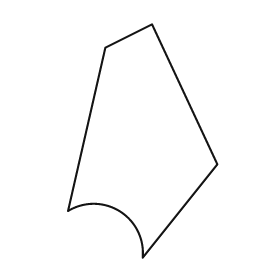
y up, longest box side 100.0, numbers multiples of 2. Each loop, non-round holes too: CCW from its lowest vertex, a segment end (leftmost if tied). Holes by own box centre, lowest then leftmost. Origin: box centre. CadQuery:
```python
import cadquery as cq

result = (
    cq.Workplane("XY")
    .moveTo(0.0, -50.0)
    .lineTo(32.0, -10.0)
    .lineTo(4.0, 50.0)
    .lineTo(-16.0, 40.0)
    .lineTo(-32.0, -30.0)
    .threePointArc((-10.0, -30.0), (0.0, -50.0))
    .close()
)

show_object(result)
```